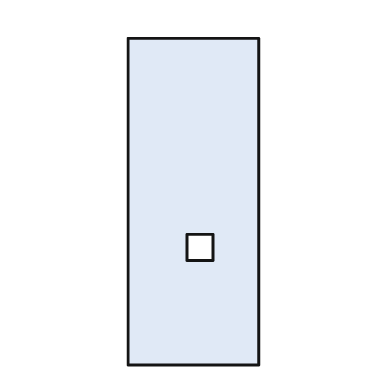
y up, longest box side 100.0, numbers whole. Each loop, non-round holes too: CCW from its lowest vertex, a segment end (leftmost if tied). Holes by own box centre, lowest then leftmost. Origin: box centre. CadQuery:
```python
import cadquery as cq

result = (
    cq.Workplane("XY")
    .moveTo(-20.0, -50.0)
    .lineTo(20.0, -50.0)
    .lineTo(20.0, 50.0)
    .lineTo(-20.0, 50.0)
    .close()
    .moveTo(-2.0, -18.0)
    .lineTo(6.0, -18.0)
    .lineTo(6.0, -10.0)
    .lineTo(-2.0, -10.0)
    .close()
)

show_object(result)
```